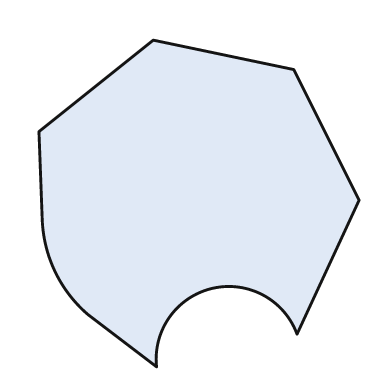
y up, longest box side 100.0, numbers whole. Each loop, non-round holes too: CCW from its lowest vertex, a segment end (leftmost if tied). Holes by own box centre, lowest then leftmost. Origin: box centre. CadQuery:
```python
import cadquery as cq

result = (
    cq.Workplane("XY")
    .moveTo(-13.0, -50.0)
    .threePointArc((4.0, -26.0), (30.0, -40.0))
    .lineTo(49.0, 1.0)
    .lineTo(29.0, 41.0)
    .lineTo(-14.0, 50.0)
    .lineTo(-49.0, 22.0)
    .lineTo(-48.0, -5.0)
    .threePointArc((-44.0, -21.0), (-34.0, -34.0))
    .close()
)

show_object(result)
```